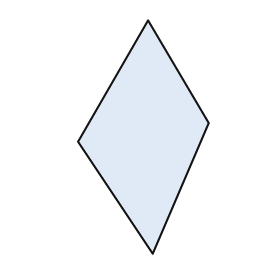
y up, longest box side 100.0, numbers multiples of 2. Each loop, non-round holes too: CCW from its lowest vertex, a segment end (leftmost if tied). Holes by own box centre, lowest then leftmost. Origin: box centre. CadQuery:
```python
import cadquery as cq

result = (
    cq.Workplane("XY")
    .moveTo(4.0, -50.0)
    .lineTo(28.0, 6.0)
    .lineTo(2.0, 50.0)
    .lineTo(-28.0, -2.0)
    .close()
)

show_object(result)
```